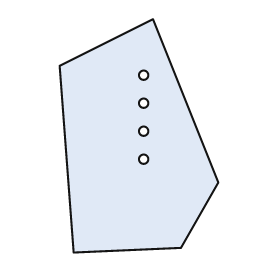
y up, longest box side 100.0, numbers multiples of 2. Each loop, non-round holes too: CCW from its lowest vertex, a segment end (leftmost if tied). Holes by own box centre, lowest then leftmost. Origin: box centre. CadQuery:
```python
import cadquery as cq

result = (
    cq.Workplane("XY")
    .moveTo(-28.0, -50.0)
    .lineTo(18.0, -48.0)
    .lineTo(34.0, -20.0)
    .lineTo(6.0, 50.0)
    .lineTo(-34.0, 30.0)
    .close()
    .moveTo(2.0, -10.0)
    .circle(2.0)
    .moveTo(2.0, 2.0)
    .circle(2.0)
    .moveTo(2.0, 14.0)
    .circle(2.0)
    .moveTo(2.0, 26.0)
    .circle(2.0)
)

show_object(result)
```